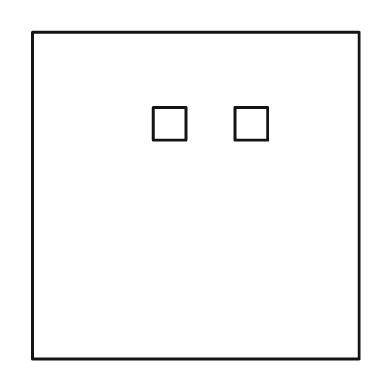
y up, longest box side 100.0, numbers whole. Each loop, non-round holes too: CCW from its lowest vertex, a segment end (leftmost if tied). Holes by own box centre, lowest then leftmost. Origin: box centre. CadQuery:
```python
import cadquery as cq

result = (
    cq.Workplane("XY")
    .moveTo(-50.0, -50.0)
    .lineTo(50.0, -50.0)
    .lineTo(50.0, 50.0)
    .lineTo(-50.0, 50.0)
    .close()
    .moveTo(-13.0, 17.0)
    .lineTo(-3.0, 17.0)
    .lineTo(-3.0, 27.0)
    .lineTo(-13.0, 27.0)
    .close()
    .moveTo(12.0, 17.0)
    .lineTo(22.0, 17.0)
    .lineTo(22.0, 27.0)
    .lineTo(12.0, 27.0)
    .close()
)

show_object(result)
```